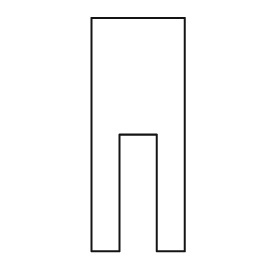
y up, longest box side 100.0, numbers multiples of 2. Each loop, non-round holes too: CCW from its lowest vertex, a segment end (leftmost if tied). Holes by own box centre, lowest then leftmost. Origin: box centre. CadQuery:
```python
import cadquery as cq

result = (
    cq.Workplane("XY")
    .moveTo(-20.0, -50.0)
    .lineTo(-8.0, -50.0)
    .lineTo(-8.0, 0.0)
    .lineTo(8.0, 0.0)
    .lineTo(8.0, -50.0)
    .lineTo(20.0, -50.0)
    .lineTo(20.0, 50.0)
    .lineTo(-20.0, 50.0)
    .close()
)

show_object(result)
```